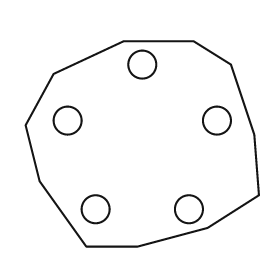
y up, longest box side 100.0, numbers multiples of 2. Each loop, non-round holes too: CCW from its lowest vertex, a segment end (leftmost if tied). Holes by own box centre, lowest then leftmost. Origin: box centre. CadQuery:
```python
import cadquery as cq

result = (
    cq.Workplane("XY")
    .moveTo(-24.0, -44.0)
    .lineTo(-2.0, -44.0)
    .lineTo(28.0, -36.0)
    .lineTo(50.0, -22.0)
    .lineTo(48.0, 4.0)
    .lineTo(38.0, 34.0)
    .lineTo(22.0, 44.0)
    .lineTo(-8.0, 44.0)
    .lineTo(-38.0, 30.0)
    .lineTo(-50.0, 8.0)
    .lineTo(-44.0, -16.0)
    .close()
    .moveTo(-20.0, -28.0)
    .circle(6.0)
    .moveTo(20.0, -28.0)
    .circle(6.0)
    .moveTo(-32.0, 10.0)
    .circle(6.0)
    .moveTo(32.0, 10.0)
    .circle(6.0)
    .moveTo(0.0, 34.0)
    .circle(6.0)
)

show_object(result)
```